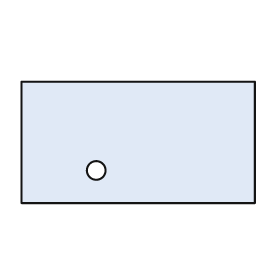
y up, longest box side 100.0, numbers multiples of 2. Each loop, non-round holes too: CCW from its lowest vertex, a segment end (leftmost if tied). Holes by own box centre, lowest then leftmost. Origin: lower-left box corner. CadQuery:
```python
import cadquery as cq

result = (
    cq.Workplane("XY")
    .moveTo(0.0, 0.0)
    .lineTo(100.0, 0.0)
    .lineTo(100.0, 52.0)
    .lineTo(0.0, 52.0)
    .close()
    .moveTo(32.0, 14.0)
    .circle(4.0)
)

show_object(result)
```